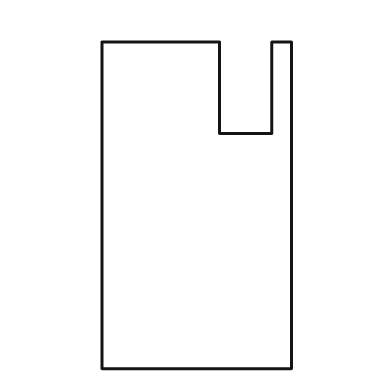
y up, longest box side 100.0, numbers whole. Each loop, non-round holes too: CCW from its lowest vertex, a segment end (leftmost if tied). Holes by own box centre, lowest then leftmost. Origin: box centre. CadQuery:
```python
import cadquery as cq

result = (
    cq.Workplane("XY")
    .moveTo(-29.0, -50.0)
    .lineTo(29.0, -50.0)
    .lineTo(29.0, 50.0)
    .lineTo(23.0, 50.0)
    .lineTo(23.0, 22.0)
    .lineTo(7.0, 22.0)
    .lineTo(7.0, 50.0)
    .lineTo(-29.0, 50.0)
    .close()
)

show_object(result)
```